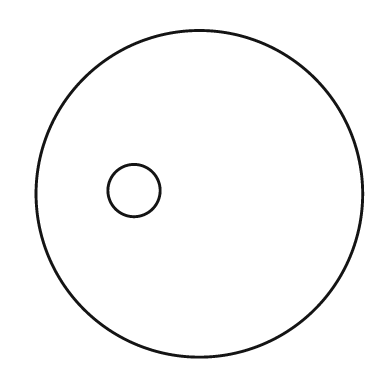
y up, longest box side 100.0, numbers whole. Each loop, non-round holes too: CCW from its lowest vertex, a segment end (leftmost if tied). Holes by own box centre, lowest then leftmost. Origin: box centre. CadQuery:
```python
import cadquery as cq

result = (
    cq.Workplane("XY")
    .moveTo(0.0, 0.0)
    .circle(50.0)
    .moveTo(-20.0, 1.0)
    .circle(8.0)
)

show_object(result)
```